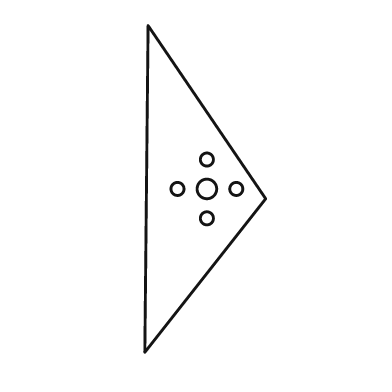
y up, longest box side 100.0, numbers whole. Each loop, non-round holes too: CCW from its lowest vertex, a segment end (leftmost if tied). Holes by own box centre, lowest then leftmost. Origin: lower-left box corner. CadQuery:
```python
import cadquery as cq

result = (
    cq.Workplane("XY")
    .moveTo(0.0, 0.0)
    .lineTo(37.0, 47.0)
    .lineTo(1.0, 100.0)
    .close()
    .moveTo(19.0, 41.0)
    .circle(2.0)
    .moveTo(10.0, 50.0)
    .circle(2.0)
    .moveTo(19.0, 50.0)
    .circle(3.0)
    .moveTo(28.0, 50.0)
    .circle(2.0)
    .moveTo(19.0, 59.0)
    .circle(2.0)
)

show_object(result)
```